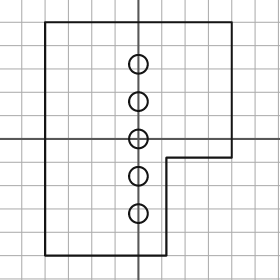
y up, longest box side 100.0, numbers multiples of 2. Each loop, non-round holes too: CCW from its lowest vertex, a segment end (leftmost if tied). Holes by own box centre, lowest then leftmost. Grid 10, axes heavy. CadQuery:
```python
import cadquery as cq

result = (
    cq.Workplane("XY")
    .moveTo(-40.0, -50.0)
    .lineTo(12.0, -50.0)
    .lineTo(12.0, -8.0)
    .lineTo(40.0, -8.0)
    .lineTo(40.0, 50.0)
    .lineTo(-40.0, 50.0)
    .close()
    .moveTo(0.0, -32.0)
    .circle(4.0)
    .moveTo(0.0, -16.0)
    .circle(4.0)
    .moveTo(0.0, 0.0)
    .circle(4.0)
    .moveTo(0.0, 16.0)
    .circle(4.0)
    .moveTo(0.0, 32.0)
    .circle(4.0)
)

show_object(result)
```